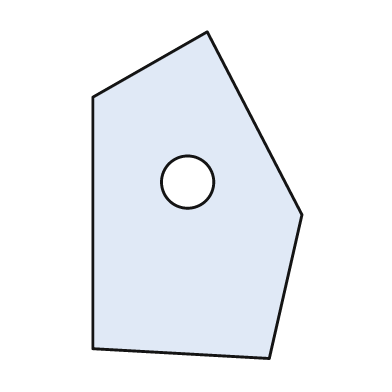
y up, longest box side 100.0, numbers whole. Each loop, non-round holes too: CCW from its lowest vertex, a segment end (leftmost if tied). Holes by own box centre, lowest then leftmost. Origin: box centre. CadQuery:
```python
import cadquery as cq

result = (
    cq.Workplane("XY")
    .moveTo(22.0, -50.0)
    .lineTo(32.0, -6.0)
    .lineTo(3.0, 50.0)
    .lineTo(-32.0, 30.0)
    .lineTo(-32.0, -47.0)
    .close()
    .moveTo(-3.0, 4.0)
    .circle(8.0)
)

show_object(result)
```